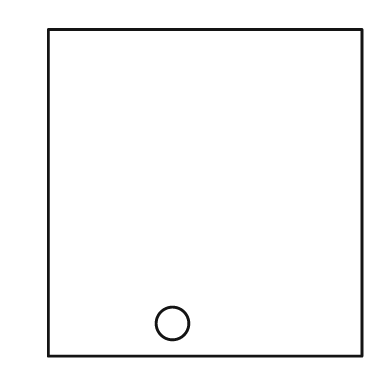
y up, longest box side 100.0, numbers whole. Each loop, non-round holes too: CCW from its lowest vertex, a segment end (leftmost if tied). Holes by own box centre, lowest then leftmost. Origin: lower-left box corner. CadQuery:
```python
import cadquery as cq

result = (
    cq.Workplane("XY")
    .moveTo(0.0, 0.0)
    .lineTo(96.0, 0.0)
    .lineTo(96.0, 100.0)
    .lineTo(0.0, 100.0)
    .close()
    .moveTo(38.0, 10.0)
    .circle(5.0)
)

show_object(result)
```